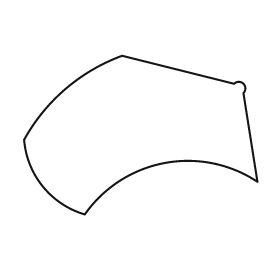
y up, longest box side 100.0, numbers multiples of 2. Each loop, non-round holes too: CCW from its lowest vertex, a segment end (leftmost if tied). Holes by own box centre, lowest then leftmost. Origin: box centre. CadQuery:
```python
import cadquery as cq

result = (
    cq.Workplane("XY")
    .moveTo(-24.0, -34.0)
    .threePointArc((10.0, -12.0), (50.0, -20.0))
    .lineTo(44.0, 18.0)
    .threePointArc((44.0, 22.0), (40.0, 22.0))
    .lineTo(-8.0, 34.0)
    .threePointArc((-32.0, 20.0), (-50.0, -2.0))
    .threePointArc((-42.0, -22.0), (-24.0, -34.0))
    .close()
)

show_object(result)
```